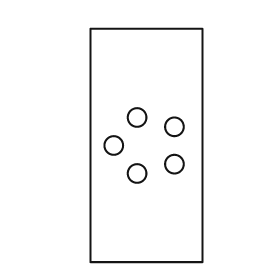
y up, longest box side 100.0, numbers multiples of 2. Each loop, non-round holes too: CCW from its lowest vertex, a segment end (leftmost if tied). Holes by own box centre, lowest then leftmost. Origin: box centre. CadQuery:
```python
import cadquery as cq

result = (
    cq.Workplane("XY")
    .moveTo(-24.0, -50.0)
    .lineTo(24.0, -50.0)
    .lineTo(24.0, 50.0)
    .lineTo(-24.0, 50.0)
    .close()
    .moveTo(-4.0, -12.0)
    .circle(4.0)
    .moveTo(12.0, -8.0)
    .circle(4.0)
    .moveTo(-14.0, 0.0)
    .circle(4.0)
    .moveTo(12.0, 8.0)
    .circle(4.0)
    .moveTo(-4.0, 12.0)
    .circle(4.0)
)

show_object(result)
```